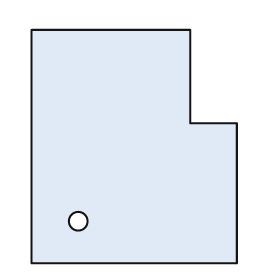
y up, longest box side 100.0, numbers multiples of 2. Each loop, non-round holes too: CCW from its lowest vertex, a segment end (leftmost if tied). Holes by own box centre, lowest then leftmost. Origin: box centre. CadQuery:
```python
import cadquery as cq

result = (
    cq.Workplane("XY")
    .moveTo(-44.0, -50.0)
    .lineTo(44.0, -50.0)
    .lineTo(44.0, 10.0)
    .lineTo(24.0, 10.0)
    .lineTo(24.0, 50.0)
    .lineTo(-44.0, 50.0)
    .close()
    .moveTo(-24.0, -32.0)
    .circle(4.0)
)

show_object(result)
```